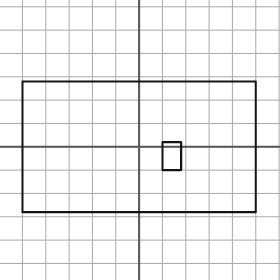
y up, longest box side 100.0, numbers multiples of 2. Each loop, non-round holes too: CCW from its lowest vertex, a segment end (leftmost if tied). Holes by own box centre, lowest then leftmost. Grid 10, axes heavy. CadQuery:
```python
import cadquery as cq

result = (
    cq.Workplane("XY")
    .moveTo(-50.0, -28.0)
    .lineTo(50.0, -28.0)
    .lineTo(50.0, 28.0)
    .lineTo(-50.0, 28.0)
    .close()
    .moveTo(10.0, -10.0)
    .lineTo(18.0, -10.0)
    .lineTo(18.0, 2.0)
    .lineTo(10.0, 2.0)
    .close()
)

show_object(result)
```